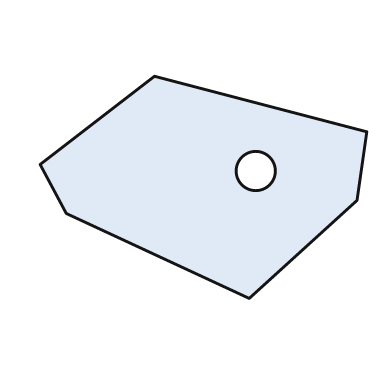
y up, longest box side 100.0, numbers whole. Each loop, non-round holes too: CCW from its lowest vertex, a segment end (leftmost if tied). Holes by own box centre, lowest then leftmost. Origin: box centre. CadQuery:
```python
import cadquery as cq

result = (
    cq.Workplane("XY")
    .moveTo(14.0, -34.0)
    .lineTo(47.0, -4.0)
    .lineTo(50.0, 17.0)
    .lineTo(-15.0, 34.0)
    .lineTo(-50.0, 7.0)
    .lineTo(-42.0, -8.0)
    .close()
    .moveTo(16.0, 5.0)
    .circle(6.0)
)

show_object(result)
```